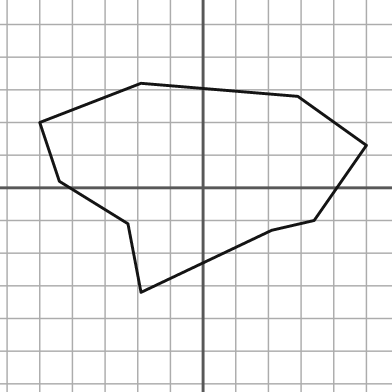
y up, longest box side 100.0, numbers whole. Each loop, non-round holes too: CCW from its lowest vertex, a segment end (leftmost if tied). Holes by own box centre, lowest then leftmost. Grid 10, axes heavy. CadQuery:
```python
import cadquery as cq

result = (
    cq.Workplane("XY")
    .moveTo(-19.0, -32.0)
    .lineTo(21.0, -13.0)
    .lineTo(34.0, -10.0)
    .lineTo(50.0, 13.0)
    .lineTo(29.0, 28.0)
    .lineTo(-19.0, 32.0)
    .lineTo(-50.0, 20.0)
    .lineTo(-44.0, 2.0)
    .lineTo(-23.0, -11.0)
    .close()
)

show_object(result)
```